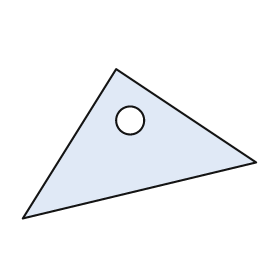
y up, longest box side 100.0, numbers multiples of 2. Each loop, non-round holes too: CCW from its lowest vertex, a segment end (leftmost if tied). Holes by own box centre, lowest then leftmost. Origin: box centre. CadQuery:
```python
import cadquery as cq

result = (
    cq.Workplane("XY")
    .moveTo(-50.0, -32.0)
    .lineTo(50.0, -8.0)
    .lineTo(-10.0, 32.0)
    .close()
    .moveTo(-4.0, 10.0)
    .circle(6.0)
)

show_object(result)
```